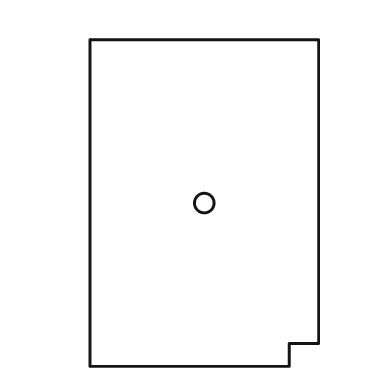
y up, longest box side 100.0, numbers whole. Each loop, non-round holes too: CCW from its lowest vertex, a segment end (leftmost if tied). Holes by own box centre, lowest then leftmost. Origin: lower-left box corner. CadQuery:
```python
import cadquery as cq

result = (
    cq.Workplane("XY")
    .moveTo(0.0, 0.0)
    .lineTo(61.0, 0.0)
    .lineTo(61.0, 7.0)
    .lineTo(70.0, 7.0)
    .lineTo(70.0, 100.0)
    .lineTo(0.0, 100.0)
    .close()
    .moveTo(35.0, 50.0)
    .circle(3.0)
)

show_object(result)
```